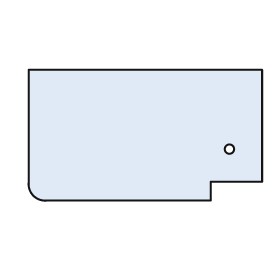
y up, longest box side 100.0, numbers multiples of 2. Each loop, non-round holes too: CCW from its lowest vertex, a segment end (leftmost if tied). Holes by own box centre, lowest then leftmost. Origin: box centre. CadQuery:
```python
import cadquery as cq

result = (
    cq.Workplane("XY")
    .moveTo(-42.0, -28.0)
    .lineTo(28.0, -28.0)
    .lineTo(28.0, -20.0)
    .lineTo(50.0, -20.0)
    .lineTo(50.0, 28.0)
    .lineTo(-50.0, 28.0)
    .lineTo(-50.0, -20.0)
    .threePointArc((-48.0, -26.0), (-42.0, -28.0))
    .close()
    .moveTo(36.0, -6.0)
    .circle(2.0)
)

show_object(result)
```